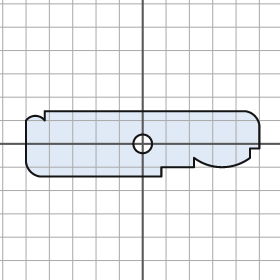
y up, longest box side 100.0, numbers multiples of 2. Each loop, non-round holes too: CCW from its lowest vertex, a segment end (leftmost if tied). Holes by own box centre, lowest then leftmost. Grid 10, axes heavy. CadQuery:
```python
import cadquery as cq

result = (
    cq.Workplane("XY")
    .moveTo(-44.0, -14.0)
    .lineTo(8.0, -14.0)
    .lineTo(8.0, -10.0)
    .lineTo(22.0, -10.0)
    .lineTo(22.0, -6.0)
    .threePointArc((34.0, -10.0), (46.0, -6.0))
    .lineTo(46.0, -2.0)
    .lineTo(50.0, -2.0)
    .lineTo(50.0, 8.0)
    .threePointArc((48.0, 12.0), (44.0, 14.0))
    .lineTo(-42.0, 14.0)
    .lineTo(-42.0, 10.0)
    .threePointArc((-46.0, 12.0), (-50.0, 10.0))
    .lineTo(-50.0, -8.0)
    .threePointArc((-48.0, -12.0), (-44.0, -14.0))
    .close()
    .moveTo(0.0, 0.0)
    .circle(4.0)
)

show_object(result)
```